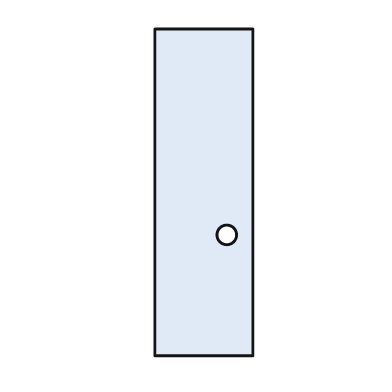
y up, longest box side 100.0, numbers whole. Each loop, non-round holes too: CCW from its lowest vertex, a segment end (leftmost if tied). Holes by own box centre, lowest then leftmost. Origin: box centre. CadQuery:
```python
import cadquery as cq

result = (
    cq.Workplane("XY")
    .moveTo(-15.0, -50.0)
    .lineTo(15.0, -50.0)
    .lineTo(15.0, 50.0)
    .lineTo(-15.0, 50.0)
    .close()
    .moveTo(7.0, -13.0)
    .circle(3.0)
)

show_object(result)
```